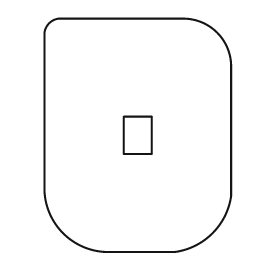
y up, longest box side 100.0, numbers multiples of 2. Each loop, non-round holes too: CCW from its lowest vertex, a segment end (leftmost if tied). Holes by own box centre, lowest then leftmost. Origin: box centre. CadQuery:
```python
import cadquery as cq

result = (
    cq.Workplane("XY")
    .moveTo(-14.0, -50.0)
    .lineTo(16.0, -50.0)
    .threePointArc((32.0, -42.0), (40.0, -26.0))
    .lineTo(40.0, 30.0)
    .threePointArc((34.0, 44.0), (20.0, 50.0))
    .lineTo(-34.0, 50.0)
    .threePointArc((-38.0, 48.0), (-40.0, 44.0))
    .lineTo(-40.0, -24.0)
    .threePointArc((-32.0, -42.0), (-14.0, -50.0))
    .close()
    .moveTo(-6.0, -8.0)
    .lineTo(6.0, -8.0)
    .lineTo(6.0, 8.0)
    .lineTo(-6.0, 8.0)
    .close()
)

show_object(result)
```